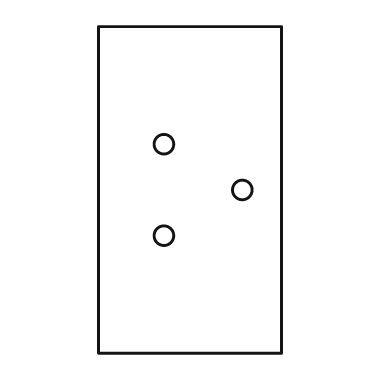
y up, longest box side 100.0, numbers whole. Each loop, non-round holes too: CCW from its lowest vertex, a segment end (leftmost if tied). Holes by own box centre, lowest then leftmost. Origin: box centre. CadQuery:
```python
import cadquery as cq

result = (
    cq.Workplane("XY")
    .moveTo(-28.0, -50.0)
    .lineTo(28.0, -50.0)
    .lineTo(28.0, 50.0)
    .lineTo(-28.0, 50.0)
    .close()
    .moveTo(-8.0, -14.0)
    .circle(3.0)
    .moveTo(16.0, 0.0)
    .circle(3.0)
    .moveTo(-8.0, 14.0)
    .circle(3.0)
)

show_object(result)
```